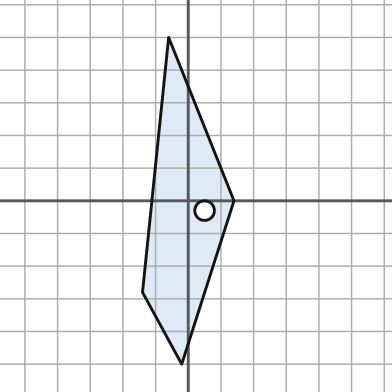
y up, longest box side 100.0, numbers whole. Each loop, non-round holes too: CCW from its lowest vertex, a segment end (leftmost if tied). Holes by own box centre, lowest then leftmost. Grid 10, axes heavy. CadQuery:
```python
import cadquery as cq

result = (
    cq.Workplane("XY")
    .moveTo(-2.0, -50.0)
    .lineTo(14.0, 0.0)
    .lineTo(-6.0, 50.0)
    .lineTo(-14.0, -28.0)
    .close()
    .moveTo(5.0, -3.0)
    .circle(3.0)
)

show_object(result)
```